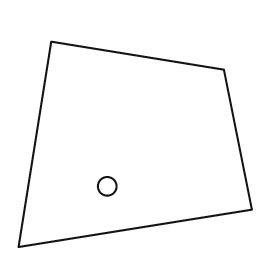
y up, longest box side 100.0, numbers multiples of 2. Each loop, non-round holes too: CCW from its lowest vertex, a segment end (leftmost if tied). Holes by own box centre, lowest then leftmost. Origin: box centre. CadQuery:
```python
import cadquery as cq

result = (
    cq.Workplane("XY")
    .moveTo(-50.0, -44.0)
    .lineTo(50.0, -28.0)
    .lineTo(38.0, 32.0)
    .lineTo(-36.0, 44.0)
    .close()
    .moveTo(-12.0, -18.0)
    .circle(4.0)
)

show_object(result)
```